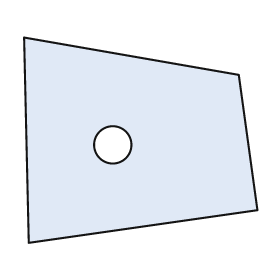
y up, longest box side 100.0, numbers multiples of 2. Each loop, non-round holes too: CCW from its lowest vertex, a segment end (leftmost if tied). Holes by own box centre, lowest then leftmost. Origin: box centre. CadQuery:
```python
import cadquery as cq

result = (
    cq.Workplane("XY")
    .moveTo(-48.0, -44.0)
    .lineTo(50.0, -30.0)
    .lineTo(42.0, 28.0)
    .lineTo(-50.0, 44.0)
    .close()
    .moveTo(-12.0, -2.0)
    .circle(8.0)
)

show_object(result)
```